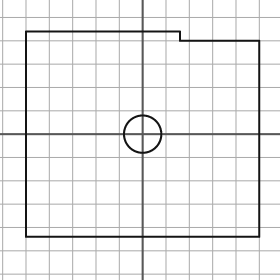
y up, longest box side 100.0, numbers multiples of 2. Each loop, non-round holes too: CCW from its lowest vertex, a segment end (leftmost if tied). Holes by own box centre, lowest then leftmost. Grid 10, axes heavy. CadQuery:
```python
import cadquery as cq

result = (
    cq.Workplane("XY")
    .moveTo(-50.0, -44.0)
    .lineTo(50.0, -44.0)
    .lineTo(50.0, 40.0)
    .lineTo(16.0, 40.0)
    .lineTo(16.0, 44.0)
    .lineTo(-50.0, 44.0)
    .close()
    .moveTo(0.0, 0.0)
    .circle(8.0)
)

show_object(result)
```